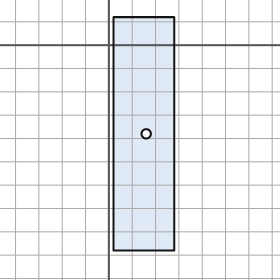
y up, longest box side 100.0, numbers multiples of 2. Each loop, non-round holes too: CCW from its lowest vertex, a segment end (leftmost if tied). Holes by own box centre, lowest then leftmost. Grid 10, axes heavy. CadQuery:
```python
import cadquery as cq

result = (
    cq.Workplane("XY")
    .moveTo(2.0, -88.0)
    .lineTo(28.0, -88.0)
    .lineTo(28.0, 12.0)
    .lineTo(2.0, 12.0)
    .close()
    .moveTo(16.0, -38.0)
    .circle(2.0)
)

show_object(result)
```